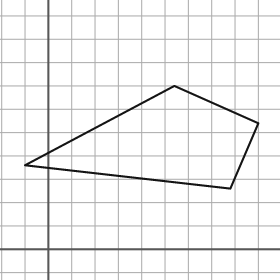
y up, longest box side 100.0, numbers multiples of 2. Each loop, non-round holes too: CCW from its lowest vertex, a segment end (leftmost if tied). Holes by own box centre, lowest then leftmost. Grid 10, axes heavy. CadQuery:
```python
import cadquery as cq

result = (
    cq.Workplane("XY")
    .moveTo(78.0, 26.0)
    .lineTo(90.0, 54.0)
    .lineTo(54.0, 70.0)
    .lineTo(-10.0, 36.0)
    .close()
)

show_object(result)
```